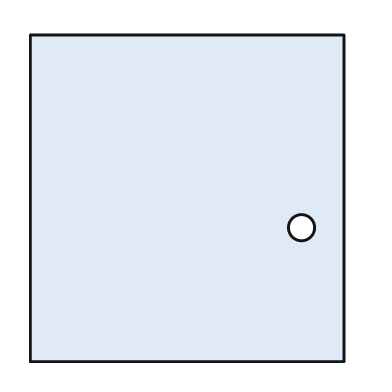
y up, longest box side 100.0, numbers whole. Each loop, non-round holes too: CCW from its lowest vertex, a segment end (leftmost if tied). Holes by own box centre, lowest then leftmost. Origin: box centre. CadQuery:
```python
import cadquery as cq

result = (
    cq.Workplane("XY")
    .moveTo(-48.0, -50.0)
    .lineTo(48.0, -50.0)
    .lineTo(48.0, 50.0)
    .lineTo(-48.0, 50.0)
    .close()
    .moveTo(35.0, -9.0)
    .circle(4.0)
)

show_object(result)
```